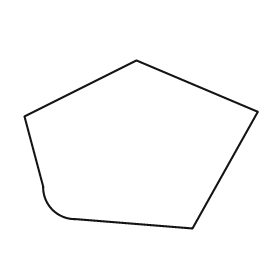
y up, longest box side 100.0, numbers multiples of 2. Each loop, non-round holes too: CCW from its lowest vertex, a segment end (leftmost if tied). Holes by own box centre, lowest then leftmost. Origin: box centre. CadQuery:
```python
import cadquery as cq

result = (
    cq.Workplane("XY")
    .moveTo(22.0, -36.0)
    .lineTo(50.0, 14.0)
    .lineTo(-2.0, 36.0)
    .lineTo(-50.0, 12.0)
    .lineTo(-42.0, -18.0)
    .threePointArc((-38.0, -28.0), (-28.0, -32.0))
    .close()
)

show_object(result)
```